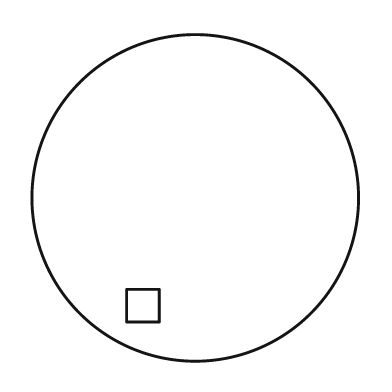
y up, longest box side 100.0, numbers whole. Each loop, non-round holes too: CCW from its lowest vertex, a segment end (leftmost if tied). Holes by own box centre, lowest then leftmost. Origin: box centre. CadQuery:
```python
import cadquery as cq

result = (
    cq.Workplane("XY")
    .moveTo(0.0, 0.0)
    .circle(50.0)
    .moveTo(-21.0, -38.0)
    .lineTo(-11.0, -38.0)
    .lineTo(-11.0, -28.0)
    .lineTo(-21.0, -28.0)
    .close()
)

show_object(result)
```